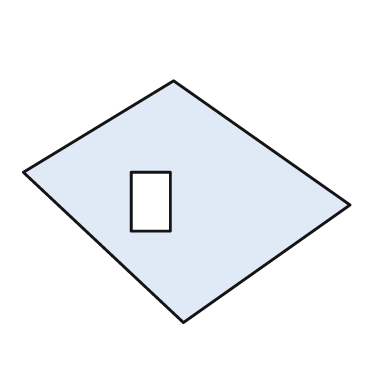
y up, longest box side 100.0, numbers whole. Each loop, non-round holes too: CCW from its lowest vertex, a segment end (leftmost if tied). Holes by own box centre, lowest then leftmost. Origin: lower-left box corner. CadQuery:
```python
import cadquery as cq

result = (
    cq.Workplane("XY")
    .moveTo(49.0, 0.0)
    .lineTo(100.0, 36.0)
    .lineTo(46.0, 74.0)
    .lineTo(0.0, 46.0)
    .close()
    .moveTo(33.0, 28.0)
    .lineTo(45.0, 28.0)
    .lineTo(45.0, 46.0)
    .lineTo(33.0, 46.0)
    .close()
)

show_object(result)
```